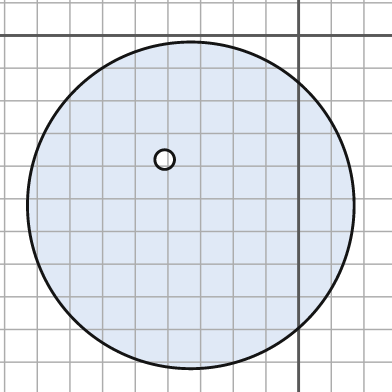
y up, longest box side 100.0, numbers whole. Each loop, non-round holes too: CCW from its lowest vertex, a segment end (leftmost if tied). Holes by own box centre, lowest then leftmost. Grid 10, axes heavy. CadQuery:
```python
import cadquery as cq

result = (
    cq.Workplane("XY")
    .moveTo(-33.0, -52.0)
    .circle(50.0)
    .moveTo(-41.0, -38.0)
    .circle(3.0)
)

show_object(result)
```